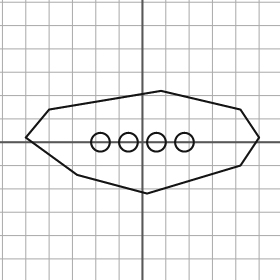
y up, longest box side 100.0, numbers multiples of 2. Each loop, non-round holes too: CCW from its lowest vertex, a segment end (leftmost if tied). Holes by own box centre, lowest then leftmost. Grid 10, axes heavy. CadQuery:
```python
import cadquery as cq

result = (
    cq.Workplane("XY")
    .moveTo(2.0, -22.0)
    .lineTo(42.0, -10.0)
    .lineTo(50.0, 2.0)
    .lineTo(42.0, 14.0)
    .lineTo(8.0, 22.0)
    .lineTo(-40.0, 14.0)
    .lineTo(-50.0, 2.0)
    .lineTo(-28.0, -14.0)
    .close()
    .moveTo(-18.0, 0.0)
    .circle(4.0)
    .moveTo(-6.0, 0.0)
    .circle(4.0)
    .moveTo(6.0, 0.0)
    .circle(4.0)
    .moveTo(18.0, 0.0)
    .circle(4.0)
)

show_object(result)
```